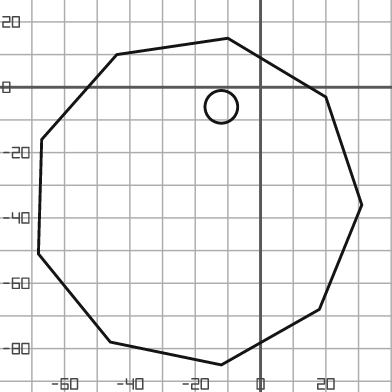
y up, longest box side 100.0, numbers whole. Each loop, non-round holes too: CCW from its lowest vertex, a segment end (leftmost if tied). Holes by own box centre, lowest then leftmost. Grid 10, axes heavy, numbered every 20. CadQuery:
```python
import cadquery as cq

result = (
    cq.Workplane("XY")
    .moveTo(-12.0, -85.0)
    .lineTo(18.0, -68.0)
    .lineTo(31.0, -36.0)
    .lineTo(20.0, -3.0)
    .lineTo(-10.0, 15.0)
    .lineTo(-44.0, 10.0)
    .lineTo(-67.0, -16.0)
    .lineTo(-68.0, -51.0)
    .lineTo(-46.0, -78.0)
    .close()
    .moveTo(-12.0, -6.0)
    .circle(5.0)
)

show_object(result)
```